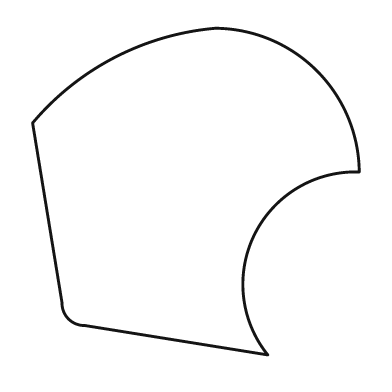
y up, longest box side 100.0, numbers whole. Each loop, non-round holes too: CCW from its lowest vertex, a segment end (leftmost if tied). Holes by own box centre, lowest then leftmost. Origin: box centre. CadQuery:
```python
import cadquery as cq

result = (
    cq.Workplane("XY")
    .moveTo(22.0, -50.0)
    .threePointArc((18.0, -13.0), (50.0, 6.0))
    .threePointArc((37.0, 37.0), (6.0, 50.0))
    .threePointArc((-25.0, 41.0), (-50.0, 21.0))
    .lineTo(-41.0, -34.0)
    .threePointArc((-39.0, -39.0), (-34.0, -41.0))
    .close()
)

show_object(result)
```